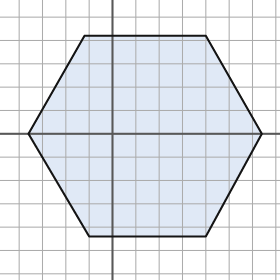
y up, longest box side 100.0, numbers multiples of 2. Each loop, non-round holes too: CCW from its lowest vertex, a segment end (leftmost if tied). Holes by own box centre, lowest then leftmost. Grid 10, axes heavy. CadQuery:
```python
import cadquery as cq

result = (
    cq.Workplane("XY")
    .moveTo(-10.0, -44.0)
    .lineTo(40.0, -44.0)
    .lineTo(64.0, 0.0)
    .lineTo(40.0, 42.0)
    .lineTo(-12.0, 42.0)
    .lineTo(-36.0, 0.0)
    .close()
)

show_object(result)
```